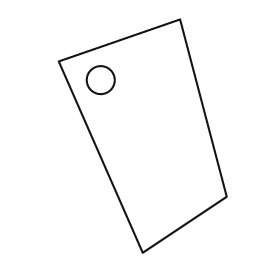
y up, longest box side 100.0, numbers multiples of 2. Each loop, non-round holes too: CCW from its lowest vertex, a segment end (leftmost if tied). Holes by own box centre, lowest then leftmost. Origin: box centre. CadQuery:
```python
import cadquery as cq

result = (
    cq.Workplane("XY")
    .moveTo(0.0, -50.0)
    .lineTo(36.0, -26.0)
    .lineTo(16.0, 50.0)
    .lineTo(-36.0, 32.0)
    .close()
    .moveTo(-18.0, 24.0)
    .circle(6.0)
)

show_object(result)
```